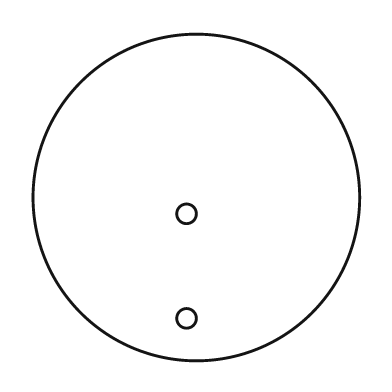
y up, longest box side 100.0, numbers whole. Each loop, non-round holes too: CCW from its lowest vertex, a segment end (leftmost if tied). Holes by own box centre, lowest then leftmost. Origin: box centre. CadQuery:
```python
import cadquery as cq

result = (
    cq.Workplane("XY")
    .moveTo(0.0, 0.0)
    .circle(50.0)
    .moveTo(-3.0, -37.0)
    .circle(3.0)
    .moveTo(-3.0, -5.0)
    .circle(3.0)
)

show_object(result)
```